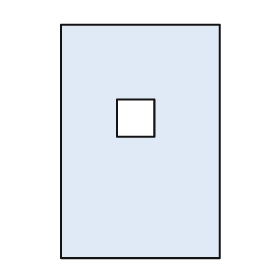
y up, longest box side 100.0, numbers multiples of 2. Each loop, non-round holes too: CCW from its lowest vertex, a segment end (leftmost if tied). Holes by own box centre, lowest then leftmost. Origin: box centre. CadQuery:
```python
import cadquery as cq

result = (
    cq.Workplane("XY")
    .moveTo(-34.0, -50.0)
    .lineTo(34.0, -50.0)
    .lineTo(34.0, 50.0)
    .lineTo(-34.0, 50.0)
    .close()
    .moveTo(-10.0, 2.0)
    .lineTo(6.0, 2.0)
    .lineTo(6.0, 18.0)
    .lineTo(-10.0, 18.0)
    .close()
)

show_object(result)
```